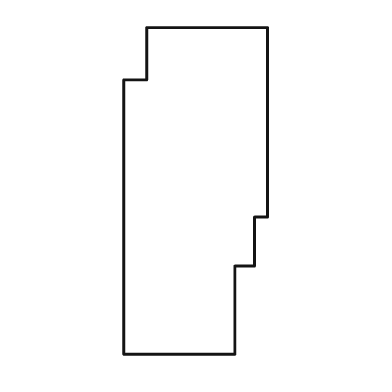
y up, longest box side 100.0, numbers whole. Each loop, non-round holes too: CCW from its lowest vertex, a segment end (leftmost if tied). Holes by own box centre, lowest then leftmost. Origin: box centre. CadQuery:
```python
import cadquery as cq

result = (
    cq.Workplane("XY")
    .moveTo(-22.0, -50.0)
    .lineTo(12.0, -50.0)
    .lineTo(12.0, -23.0)
    .lineTo(18.0, -23.0)
    .lineTo(18.0, -8.0)
    .lineTo(22.0, -8.0)
    .lineTo(22.0, 50.0)
    .lineTo(-15.0, 50.0)
    .lineTo(-15.0, 34.0)
    .lineTo(-22.0, 34.0)
    .close()
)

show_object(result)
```